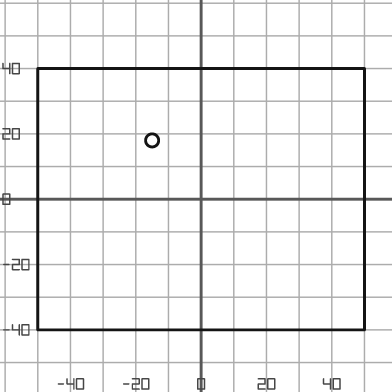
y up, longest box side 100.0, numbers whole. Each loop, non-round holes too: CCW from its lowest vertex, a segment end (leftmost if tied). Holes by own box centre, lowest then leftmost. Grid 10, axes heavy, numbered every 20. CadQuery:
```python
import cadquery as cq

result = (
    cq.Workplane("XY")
    .moveTo(-50.0, -40.0)
    .lineTo(50.0, -40.0)
    .lineTo(50.0, 40.0)
    .lineTo(-50.0, 40.0)
    .close()
    .moveTo(-15.0, 18.0)
    .circle(2.0)
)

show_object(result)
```